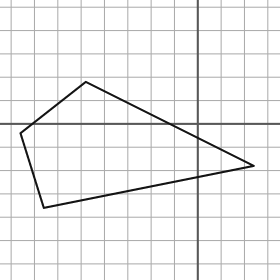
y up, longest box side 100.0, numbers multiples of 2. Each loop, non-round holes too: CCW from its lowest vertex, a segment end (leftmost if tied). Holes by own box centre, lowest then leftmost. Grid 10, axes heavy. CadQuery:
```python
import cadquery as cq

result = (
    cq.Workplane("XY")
    .moveTo(-66.0, -36.0)
    .lineTo(24.0, -18.0)
    .lineTo(-48.0, 18.0)
    .lineTo(-76.0, -4.0)
    .close()
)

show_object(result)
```